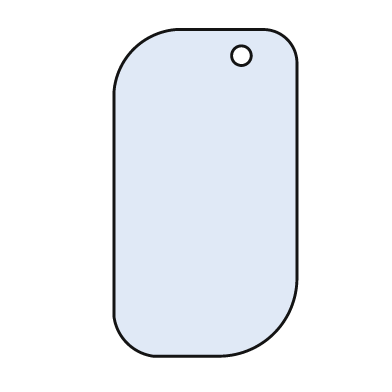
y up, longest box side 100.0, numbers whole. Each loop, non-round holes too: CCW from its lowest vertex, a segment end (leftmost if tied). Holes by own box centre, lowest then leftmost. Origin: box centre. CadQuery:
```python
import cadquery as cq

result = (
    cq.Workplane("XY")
    .moveTo(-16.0, -50.0)
    .lineTo(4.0, -50.0)
    .threePointArc((21.0, -43.0), (28.0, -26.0))
    .lineTo(28.0, 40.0)
    .threePointArc((25.0, 47.0), (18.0, 50.0))
    .lineTo(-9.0, 50.0)
    .threePointArc((-22.0, 44.0), (-28.0, 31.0))
    .lineTo(-28.0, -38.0)
    .threePointArc((-24.0, -46.0), (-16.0, -50.0))
    .close()
    .moveTo(11.0, 42.0)
    .circle(3.0)
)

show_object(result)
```